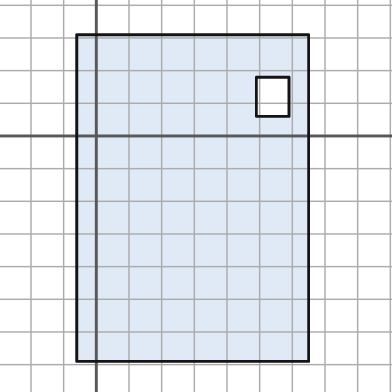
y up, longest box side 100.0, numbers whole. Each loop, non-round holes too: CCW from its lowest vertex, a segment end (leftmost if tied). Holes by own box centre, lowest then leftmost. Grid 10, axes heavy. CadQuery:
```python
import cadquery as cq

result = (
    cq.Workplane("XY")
    .moveTo(-6.0, -69.0)
    .lineTo(65.0, -69.0)
    .lineTo(65.0, 31.0)
    .lineTo(-6.0, 31.0)
    .close()
    .moveTo(49.0, 6.0)
    .lineTo(59.0, 6.0)
    .lineTo(59.0, 18.0)
    .lineTo(49.0, 18.0)
    .close()
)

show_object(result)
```